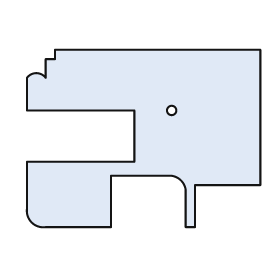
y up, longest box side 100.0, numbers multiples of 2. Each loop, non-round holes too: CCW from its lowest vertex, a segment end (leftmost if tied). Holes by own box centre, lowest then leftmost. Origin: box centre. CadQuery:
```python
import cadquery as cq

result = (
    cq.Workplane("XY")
    .moveTo(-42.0, -38.0)
    .lineTo(-14.0, -38.0)
    .lineTo(-14.0, -16.0)
    .lineTo(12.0, -16.0)
    .threePointArc((16.0, -18.0), (18.0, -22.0))
    .lineTo(18.0, -38.0)
    .lineTo(22.0, -38.0)
    .lineTo(22.0, -20.0)
    .lineTo(50.0, -20.0)
    .lineTo(50.0, 38.0)
    .lineTo(-38.0, 38.0)
    .lineTo(-38.0, 34.0)
    .lineTo(-42.0, 34.0)
    .lineTo(-42.0, 26.0)
    .threePointArc((-46.0, 28.0), (-50.0, 26.0))
    .lineTo(-50.0, 12.0)
    .lineTo(-4.0, 12.0)
    .lineTo(-4.0, -10.0)
    .lineTo(-50.0, -10.0)
    .lineTo(-50.0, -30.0)
    .threePointArc((-48.0, -36.0), (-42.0, -38.0))
    .close()
    .moveTo(12.0, 12.0)
    .circle(2.0)
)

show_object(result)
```